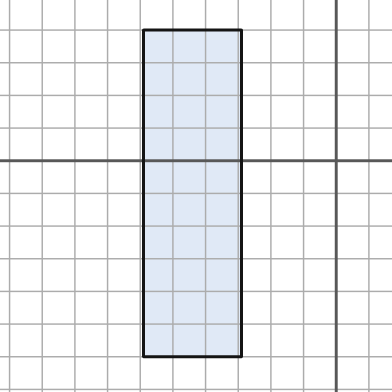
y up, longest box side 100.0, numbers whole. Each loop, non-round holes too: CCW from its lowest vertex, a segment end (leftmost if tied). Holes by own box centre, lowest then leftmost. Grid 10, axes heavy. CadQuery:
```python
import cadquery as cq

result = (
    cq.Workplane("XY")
    .moveTo(-59.0, -60.0)
    .lineTo(-29.0, -60.0)
    .lineTo(-29.0, 40.0)
    .lineTo(-59.0, 40.0)
    .close()
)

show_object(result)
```